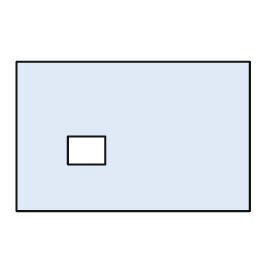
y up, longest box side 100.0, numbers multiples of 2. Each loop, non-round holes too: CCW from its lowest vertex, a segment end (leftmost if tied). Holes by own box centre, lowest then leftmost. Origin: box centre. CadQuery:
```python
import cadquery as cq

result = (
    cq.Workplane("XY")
    .moveTo(-50.0, -32.0)
    .lineTo(50.0, -32.0)
    .lineTo(50.0, 32.0)
    .lineTo(-50.0, 32.0)
    .close()
    .moveTo(-28.0, -12.0)
    .lineTo(-12.0, -12.0)
    .lineTo(-12.0, 0.0)
    .lineTo(-28.0, 0.0)
    .close()
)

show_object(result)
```